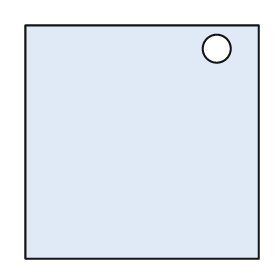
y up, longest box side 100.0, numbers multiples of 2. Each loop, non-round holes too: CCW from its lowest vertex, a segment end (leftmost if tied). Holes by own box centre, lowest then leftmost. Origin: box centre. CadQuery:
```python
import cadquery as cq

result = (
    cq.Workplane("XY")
    .moveTo(-50.0, -50.0)
    .lineTo(50.0, -50.0)
    .lineTo(50.0, 50.0)
    .lineTo(-50.0, 50.0)
    .close()
    .moveTo(32.0, 40.0)
    .circle(6.0)
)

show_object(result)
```